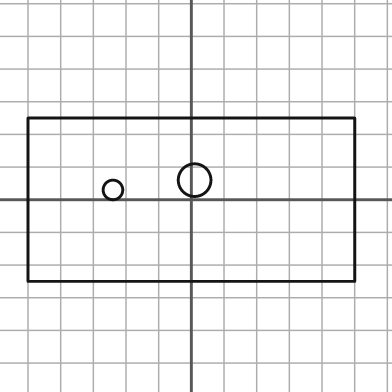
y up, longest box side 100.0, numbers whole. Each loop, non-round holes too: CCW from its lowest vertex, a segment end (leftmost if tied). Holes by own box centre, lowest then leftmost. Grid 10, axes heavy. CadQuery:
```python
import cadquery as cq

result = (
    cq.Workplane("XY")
    .moveTo(-50.0, -25.0)
    .lineTo(50.0, -25.0)
    .lineTo(50.0, 25.0)
    .lineTo(-50.0, 25.0)
    .close()
    .moveTo(-24.0, 3.0)
    .circle(3.0)
    .moveTo(1.0, 6.0)
    .circle(5.0)
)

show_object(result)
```